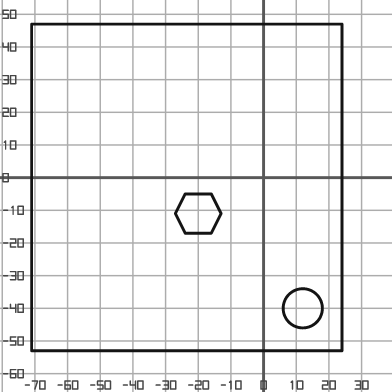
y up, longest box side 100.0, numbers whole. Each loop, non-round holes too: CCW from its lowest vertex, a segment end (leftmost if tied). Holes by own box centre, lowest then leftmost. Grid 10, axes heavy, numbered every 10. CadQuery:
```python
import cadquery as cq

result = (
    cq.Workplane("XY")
    .moveTo(-71.0, -53.0)
    .lineTo(24.0, -53.0)
    .lineTo(24.0, 47.0)
    .lineTo(-71.0, 47.0)
    .close()
    .moveTo(12.0, -40.0)
    .circle(6.0)
    .moveTo(-24.0, -17.0)
    .lineTo(-16.0, -17.0)
    .lineTo(-13.0, -11.0)
    .lineTo(-16.0, -5.0)
    .lineTo(-24.0, -5.0)
    .lineTo(-27.0, -11.0)
    .close()
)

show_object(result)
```